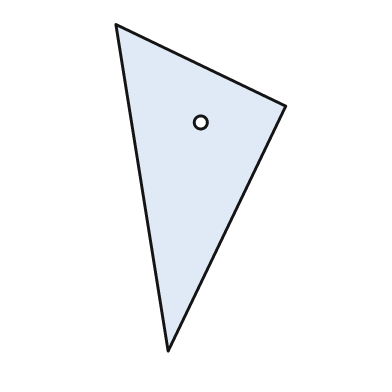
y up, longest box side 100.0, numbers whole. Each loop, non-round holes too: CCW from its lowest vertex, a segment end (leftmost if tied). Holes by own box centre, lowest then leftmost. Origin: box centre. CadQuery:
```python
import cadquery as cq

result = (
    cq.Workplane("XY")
    .moveTo(-10.0, -50.0)
    .lineTo(26.0, 25.0)
    .lineTo(-26.0, 50.0)
    .close()
    .moveTo(0.0, 20.0)
    .circle(2.0)
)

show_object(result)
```